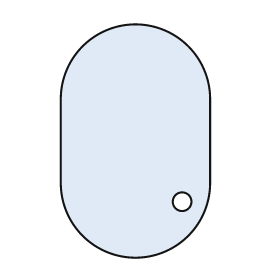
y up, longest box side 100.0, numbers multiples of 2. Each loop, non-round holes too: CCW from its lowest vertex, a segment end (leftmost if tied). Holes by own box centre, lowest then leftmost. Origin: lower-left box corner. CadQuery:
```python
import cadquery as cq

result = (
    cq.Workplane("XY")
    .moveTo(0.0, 32.0)
    .threePointArc((32.0, 0.0), (64.0, 32.0))
    .lineTo(64.0, 68.0)
    .threePointArc((32.0, 100.0), (0.0, 68.0))
    .close()
    .moveTo(52.0, 24.0)
    .circle(4.0)
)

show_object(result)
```